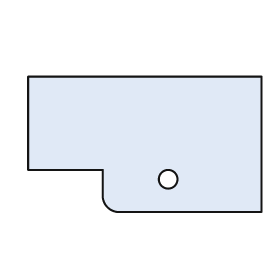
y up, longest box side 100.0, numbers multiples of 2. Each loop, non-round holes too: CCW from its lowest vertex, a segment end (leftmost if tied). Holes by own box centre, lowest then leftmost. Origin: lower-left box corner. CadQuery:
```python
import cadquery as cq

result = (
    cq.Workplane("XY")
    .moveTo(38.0, 0.0)
    .lineTo(100.0, 0.0)
    .lineTo(100.0, 58.0)
    .lineTo(0.0, 58.0)
    .lineTo(0.0, 18.0)
    .lineTo(32.0, 18.0)
    .lineTo(32.0, 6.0)
    .threePointArc((34.0, 2.0), (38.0, 0.0))
    .close()
    .moveTo(60.0, 14.0)
    .circle(4.0)
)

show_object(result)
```